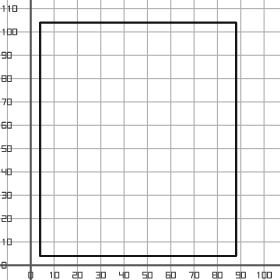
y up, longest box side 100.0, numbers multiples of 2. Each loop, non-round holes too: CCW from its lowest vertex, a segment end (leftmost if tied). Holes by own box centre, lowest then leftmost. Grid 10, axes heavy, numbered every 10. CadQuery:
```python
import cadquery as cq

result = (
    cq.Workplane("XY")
    .moveTo(4.0, 4.0)
    .lineTo(88.0, 4.0)
    .lineTo(88.0, 104.0)
    .lineTo(4.0, 104.0)
    .close()
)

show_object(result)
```